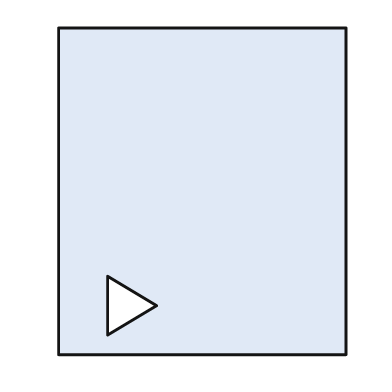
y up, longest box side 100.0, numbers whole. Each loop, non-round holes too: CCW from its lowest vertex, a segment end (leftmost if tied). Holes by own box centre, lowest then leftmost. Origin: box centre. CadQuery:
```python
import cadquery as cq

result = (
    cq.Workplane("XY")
    .moveTo(-44.0, -50.0)
    .lineTo(44.0, -50.0)
    .lineTo(44.0, 50.0)
    .lineTo(-44.0, 50.0)
    .close()
    .moveTo(-29.0, -44.0)
    .lineTo(-14.0, -35.0)
    .lineTo(-29.0, -26.0)
    .close()
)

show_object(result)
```